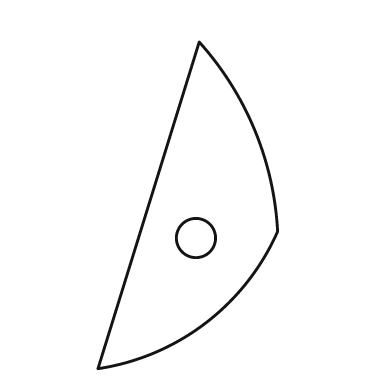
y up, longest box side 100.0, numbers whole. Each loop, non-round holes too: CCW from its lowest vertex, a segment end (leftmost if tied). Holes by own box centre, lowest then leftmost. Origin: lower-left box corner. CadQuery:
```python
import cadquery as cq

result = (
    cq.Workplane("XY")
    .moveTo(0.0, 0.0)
    .threePointArc((33.0, 14.0), (55.0, 42.0))
    .threePointArc((48.0, 73.0), (31.0, 100.0))
    .close()
    .moveTo(30.0, 40.0)
    .circle(6.0)
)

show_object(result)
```